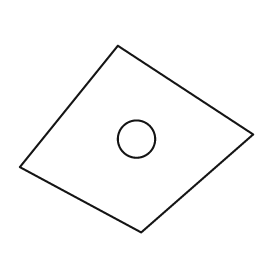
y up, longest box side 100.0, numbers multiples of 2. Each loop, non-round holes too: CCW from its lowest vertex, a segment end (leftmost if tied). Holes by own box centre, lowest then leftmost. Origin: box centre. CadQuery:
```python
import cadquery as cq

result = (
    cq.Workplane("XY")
    .moveTo(2.0, -40.0)
    .lineTo(50.0, 2.0)
    .lineTo(-8.0, 40.0)
    .lineTo(-50.0, -12.0)
    .close()
    .moveTo(0.0, 0.0)
    .circle(8.0)
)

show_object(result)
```